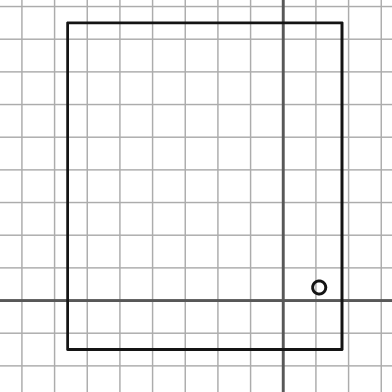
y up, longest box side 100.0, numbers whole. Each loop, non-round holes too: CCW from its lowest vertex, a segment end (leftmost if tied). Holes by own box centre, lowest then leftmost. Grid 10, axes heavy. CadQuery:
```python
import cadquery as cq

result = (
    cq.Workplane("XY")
    .moveTo(-66.0, -15.0)
    .lineTo(18.0, -15.0)
    .lineTo(18.0, 85.0)
    .lineTo(-66.0, 85.0)
    .close()
    .moveTo(11.0, 4.0)
    .circle(2.0)
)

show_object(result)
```